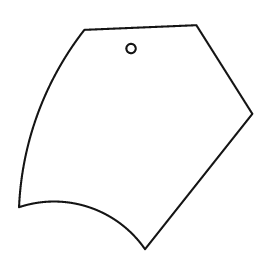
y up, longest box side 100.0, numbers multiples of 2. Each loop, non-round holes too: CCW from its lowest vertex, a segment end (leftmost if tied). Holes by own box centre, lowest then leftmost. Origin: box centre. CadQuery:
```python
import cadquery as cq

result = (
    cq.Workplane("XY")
    .moveTo(4.0, -48.0)
    .lineTo(50.0, 10.0)
    .lineTo(26.0, 48.0)
    .lineTo(-22.0, 46.0)
    .threePointArc((-42.0, 10.0), (-50.0, -30.0))
    .threePointArc((-20.0, -30.0), (4.0, -48.0))
    .close()
    .moveTo(-2.0, 38.0)
    .circle(2.0)
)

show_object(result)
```